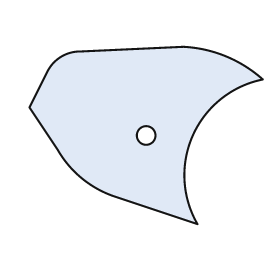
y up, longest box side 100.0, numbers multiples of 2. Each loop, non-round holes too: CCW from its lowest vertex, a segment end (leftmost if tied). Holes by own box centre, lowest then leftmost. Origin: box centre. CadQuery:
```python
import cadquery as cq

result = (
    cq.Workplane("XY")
    .moveTo(22.0, -38.0)
    .threePointArc((20.0, 0.0), (50.0, 24.0))
    .threePointArc((34.0, 34.0), (16.0, 38.0))
    .lineTo(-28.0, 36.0)
    .threePointArc((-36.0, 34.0), (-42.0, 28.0))
    .lineTo(-50.0, 12.0)
    .lineTo(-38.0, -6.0)
    .threePointArc((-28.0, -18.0), (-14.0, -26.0))
    .close()
    .moveTo(0.0, 0.0)
    .circle(4.0)
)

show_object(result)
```